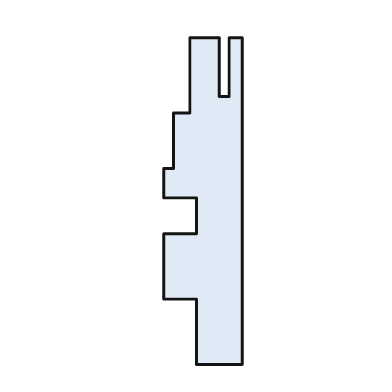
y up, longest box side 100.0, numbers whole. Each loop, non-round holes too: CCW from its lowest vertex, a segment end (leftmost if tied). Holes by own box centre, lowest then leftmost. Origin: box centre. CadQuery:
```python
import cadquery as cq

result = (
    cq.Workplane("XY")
    .moveTo(-2.0, -50.0)
    .lineTo(12.0, -50.0)
    .lineTo(12.0, 50.0)
    .lineTo(8.0, 50.0)
    .lineTo(8.0, 32.0)
    .lineTo(5.0, 32.0)
    .lineTo(5.0, 50.0)
    .lineTo(-4.0, 50.0)
    .lineTo(-4.0, 27.0)
    .lineTo(-9.0, 27.0)
    .lineTo(-9.0, 10.0)
    .lineTo(-12.0, 10.0)
    .lineTo(-12.0, 1.0)
    .lineTo(-2.0, 1.0)
    .lineTo(-2.0, -10.0)
    .lineTo(-12.0, -10.0)
    .lineTo(-12.0, -30.0)
    .lineTo(-2.0, -30.0)
    .close()
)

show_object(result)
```